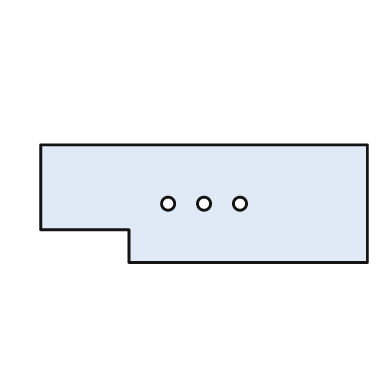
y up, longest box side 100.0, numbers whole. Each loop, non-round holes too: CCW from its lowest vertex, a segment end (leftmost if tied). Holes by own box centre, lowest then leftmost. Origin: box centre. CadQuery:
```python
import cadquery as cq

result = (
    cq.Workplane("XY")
    .moveTo(-23.0, -18.0)
    .lineTo(50.0, -18.0)
    .lineTo(50.0, 18.0)
    .lineTo(-50.0, 18.0)
    .lineTo(-50.0, -8.0)
    .lineTo(-23.0, -8.0)
    .close()
    .moveTo(-11.0, 0.0)
    .circle(2.0)
    .moveTo(0.0, 0.0)
    .circle(2.0)
    .moveTo(11.0, 0.0)
    .circle(2.0)
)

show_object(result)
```